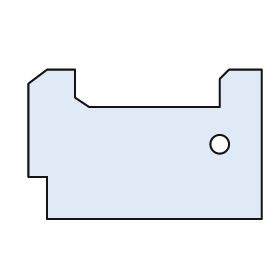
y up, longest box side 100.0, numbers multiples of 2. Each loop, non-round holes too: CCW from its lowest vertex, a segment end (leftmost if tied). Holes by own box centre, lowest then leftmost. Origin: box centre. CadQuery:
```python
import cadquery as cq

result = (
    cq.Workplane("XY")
    .moveTo(-42.0, -32.0)
    .lineTo(50.0, -32.0)
    .lineTo(50.0, 32.0)
    .lineTo(36.0, 32.0)
    .lineTo(32.0, 28.0)
    .lineTo(32.0, 16.0)
    .lineTo(-24.0, 16.0)
    .lineTo(-30.0, 20.0)
    .lineTo(-30.0, 32.0)
    .lineTo(-42.0, 32.0)
    .lineTo(-50.0, 26.0)
    .lineTo(-50.0, -14.0)
    .lineTo(-42.0, -14.0)
    .close()
    .moveTo(32.0, 0.0)
    .circle(4.0)
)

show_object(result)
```